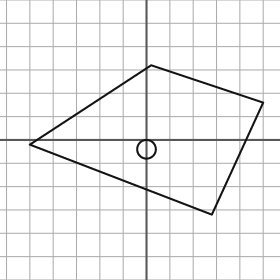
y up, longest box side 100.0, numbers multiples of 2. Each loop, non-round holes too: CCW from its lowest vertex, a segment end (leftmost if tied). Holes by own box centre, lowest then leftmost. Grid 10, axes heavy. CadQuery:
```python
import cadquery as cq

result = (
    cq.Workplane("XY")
    .moveTo(28.0, -32.0)
    .lineTo(50.0, 16.0)
    .lineTo(2.0, 32.0)
    .lineTo(-50.0, -2.0)
    .close()
    .moveTo(0.0, -4.0)
    .circle(4.0)
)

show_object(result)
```